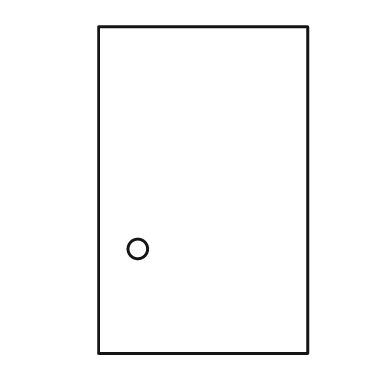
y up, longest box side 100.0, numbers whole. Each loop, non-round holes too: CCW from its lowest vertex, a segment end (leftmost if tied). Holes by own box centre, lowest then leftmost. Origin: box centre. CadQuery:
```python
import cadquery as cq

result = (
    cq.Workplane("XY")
    .moveTo(-32.0, -50.0)
    .lineTo(32.0, -50.0)
    .lineTo(32.0, 50.0)
    .lineTo(-32.0, 50.0)
    .close()
    .moveTo(-20.0, -18.0)
    .circle(3.0)
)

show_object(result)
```